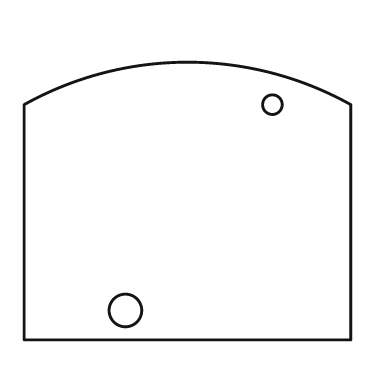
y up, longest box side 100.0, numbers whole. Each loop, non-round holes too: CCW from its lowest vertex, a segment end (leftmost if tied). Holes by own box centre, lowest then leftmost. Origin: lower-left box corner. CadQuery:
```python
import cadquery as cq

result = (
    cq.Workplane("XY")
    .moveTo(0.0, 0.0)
    .lineTo(100.0, 0.0)
    .lineTo(100.0, 72.0)
    .threePointArc((50.0, 85.0), (0.0, 72.0))
    .close()
    .moveTo(31.0, 9.0)
    .circle(5.0)
    .moveTo(76.0, 72.0)
    .circle(3.0)
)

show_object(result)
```